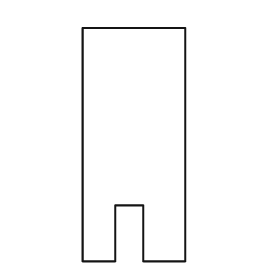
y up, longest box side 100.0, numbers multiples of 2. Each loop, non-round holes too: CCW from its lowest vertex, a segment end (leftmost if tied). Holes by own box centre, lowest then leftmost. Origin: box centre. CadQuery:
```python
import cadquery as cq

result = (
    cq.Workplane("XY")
    .moveTo(-22.0, -50.0)
    .lineTo(-8.0, -50.0)
    .lineTo(-8.0, -26.0)
    .lineTo(4.0, -26.0)
    .lineTo(4.0, -50.0)
    .lineTo(22.0, -50.0)
    .lineTo(22.0, 50.0)
    .lineTo(-22.0, 50.0)
    .close()
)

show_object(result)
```